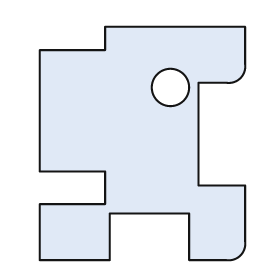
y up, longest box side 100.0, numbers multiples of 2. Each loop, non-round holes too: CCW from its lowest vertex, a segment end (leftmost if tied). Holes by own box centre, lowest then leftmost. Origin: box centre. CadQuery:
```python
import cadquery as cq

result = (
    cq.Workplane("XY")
    .moveTo(-44.0, -50.0)
    .lineTo(-14.0, -50.0)
    .lineTo(-14.0, -30.0)
    .lineTo(20.0, -30.0)
    .lineTo(20.0, -50.0)
    .lineTo(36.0, -50.0)
    .threePointArc((42.0, -48.0), (44.0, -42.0))
    .lineTo(44.0, -18.0)
    .lineTo(24.0, -18.0)
    .lineTo(24.0, 26.0)
    .lineTo(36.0, 26.0)
    .threePointArc((42.0, 28.0), (44.0, 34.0))
    .lineTo(44.0, 50.0)
    .lineTo(-16.0, 50.0)
    .lineTo(-16.0, 40.0)
    .lineTo(-44.0, 40.0)
    .lineTo(-44.0, -12.0)
    .lineTo(-16.0, -12.0)
    .lineTo(-16.0, -26.0)
    .lineTo(-44.0, -26.0)
    .close()
    .moveTo(12.0, 24.0)
    .circle(8.0)
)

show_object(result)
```